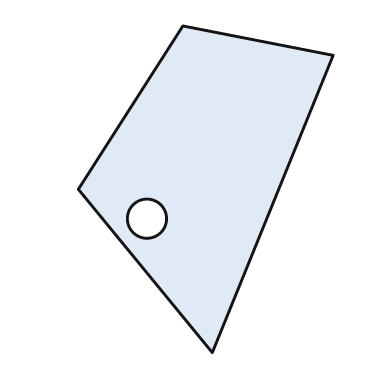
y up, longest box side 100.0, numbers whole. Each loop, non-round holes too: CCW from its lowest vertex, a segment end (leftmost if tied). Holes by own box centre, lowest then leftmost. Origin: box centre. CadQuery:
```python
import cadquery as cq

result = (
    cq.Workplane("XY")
    .moveTo(2.0, -50.0)
    .lineTo(39.0, 41.0)
    .lineTo(-7.0, 50.0)
    .lineTo(-39.0, 0.0)
    .close()
    .moveTo(-18.0, -9.0)
    .circle(6.0)
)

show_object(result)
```